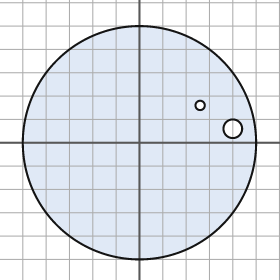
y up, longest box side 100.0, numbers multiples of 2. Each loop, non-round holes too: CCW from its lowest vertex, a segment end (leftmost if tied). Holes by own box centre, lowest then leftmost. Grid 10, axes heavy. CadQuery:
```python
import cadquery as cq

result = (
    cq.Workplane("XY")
    .moveTo(0.0, 0.0)
    .circle(50.0)
    .moveTo(40.0, 6.0)
    .circle(4.0)
    .moveTo(26.0, 16.0)
    .circle(2.0)
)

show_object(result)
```